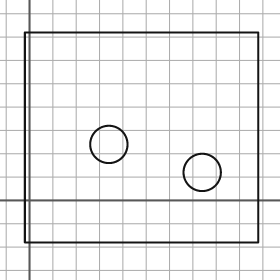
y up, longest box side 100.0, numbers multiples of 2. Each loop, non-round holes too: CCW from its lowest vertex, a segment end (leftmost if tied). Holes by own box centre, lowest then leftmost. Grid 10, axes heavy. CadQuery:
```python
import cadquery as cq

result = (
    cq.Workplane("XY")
    .moveTo(-2.0, -18.0)
    .lineTo(98.0, -18.0)
    .lineTo(98.0, 72.0)
    .lineTo(-2.0, 72.0)
    .close()
    .moveTo(74.0, 12.0)
    .circle(8.0)
    .moveTo(34.0, 24.0)
    .circle(8.0)
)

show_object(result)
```